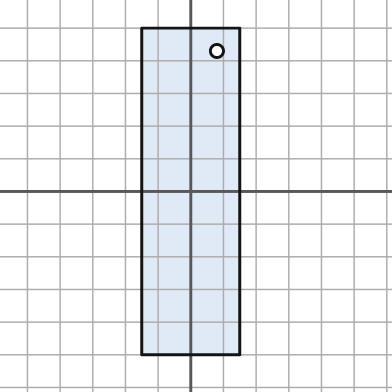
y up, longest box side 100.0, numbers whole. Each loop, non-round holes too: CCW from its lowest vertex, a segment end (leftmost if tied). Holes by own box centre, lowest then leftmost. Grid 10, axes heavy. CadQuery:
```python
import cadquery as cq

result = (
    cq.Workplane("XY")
    .moveTo(-15.0, -50.0)
    .lineTo(15.0, -50.0)
    .lineTo(15.0, 50.0)
    .lineTo(-15.0, 50.0)
    .close()
    .moveTo(8.0, 43.0)
    .circle(2.0)
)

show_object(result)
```